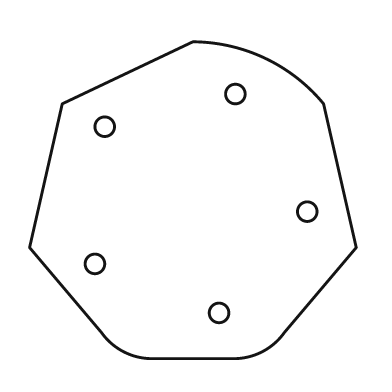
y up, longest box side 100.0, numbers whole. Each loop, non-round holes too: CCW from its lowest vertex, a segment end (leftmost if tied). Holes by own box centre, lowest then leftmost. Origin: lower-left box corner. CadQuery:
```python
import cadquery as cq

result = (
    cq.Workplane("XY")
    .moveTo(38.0, 0.0)
    .lineTo(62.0, 0.0)
    .threePointArc((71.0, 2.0), (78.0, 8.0))
    .lineTo(100.0, 34.0)
    .lineTo(90.0, 78.0)
    .threePointArc((72.0, 92.0), (50.0, 97.0))
    .lineTo(10.0, 78.0)
    .lineTo(0.0, 34.0)
    .lineTo(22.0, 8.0)
    .threePointArc((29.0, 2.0), (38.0, 0.0))
    .close()
    .moveTo(58.0, 14.0)
    .circle(3.0)
    .moveTo(20.0, 29.0)
    .circle(3.0)
    .moveTo(85.0, 45.0)
    .circle(3.0)
    .moveTo(23.0, 71.0)
    .circle(3.0)
    .moveTo(63.0, 81.0)
    .circle(3.0)
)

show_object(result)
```